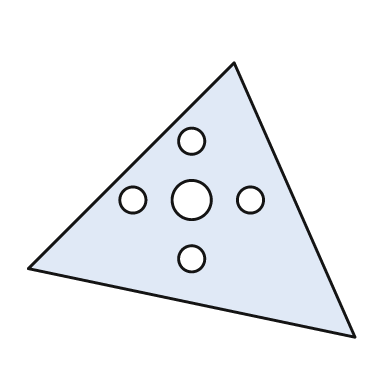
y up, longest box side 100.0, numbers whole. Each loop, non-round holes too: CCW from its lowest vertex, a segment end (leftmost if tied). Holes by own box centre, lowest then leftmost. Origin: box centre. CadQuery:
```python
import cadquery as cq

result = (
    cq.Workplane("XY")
    .moveTo(50.0, -42.0)
    .lineTo(13.0, 42.0)
    .lineTo(-50.0, -21.0)
    .close()
    .moveTo(0.0, -18.0)
    .circle(4.0)
    .moveTo(-18.0, 0.0)
    .circle(4.0)
    .moveTo(0.0, 0.0)
    .circle(6.0)
    .moveTo(18.0, 0.0)
    .circle(4.0)
    .moveTo(0.0, 18.0)
    .circle(4.0)
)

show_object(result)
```